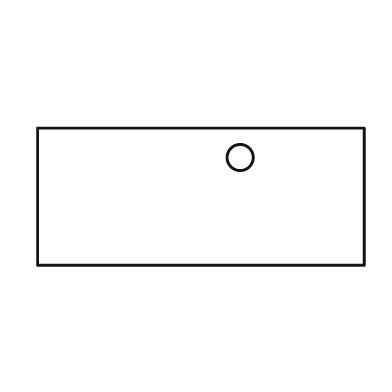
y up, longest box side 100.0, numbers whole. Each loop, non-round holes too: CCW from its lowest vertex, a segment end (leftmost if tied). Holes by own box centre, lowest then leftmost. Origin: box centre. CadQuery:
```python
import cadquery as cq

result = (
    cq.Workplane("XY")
    .moveTo(-50.0, -21.0)
    .lineTo(50.0, -21.0)
    .lineTo(50.0, 21.0)
    .lineTo(-50.0, 21.0)
    .close()
    .moveTo(12.0, 12.0)
    .circle(4.0)
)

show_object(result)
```